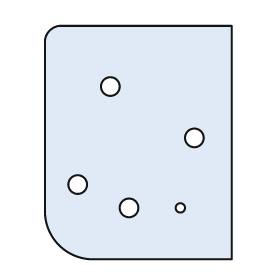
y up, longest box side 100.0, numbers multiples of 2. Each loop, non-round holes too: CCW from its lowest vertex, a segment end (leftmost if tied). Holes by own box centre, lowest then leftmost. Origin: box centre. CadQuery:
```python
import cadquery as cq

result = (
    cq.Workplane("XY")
    .moveTo(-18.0, -50.0)
    .lineTo(40.0, -50.0)
    .lineTo(40.0, 50.0)
    .lineTo(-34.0, 50.0)
    .threePointArc((-38.0, 48.0), (-40.0, 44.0))
    .lineTo(-40.0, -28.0)
    .threePointArc((-34.0, -44.0), (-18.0, -50.0))
    .close()
    .moveTo(-4.0, -28.0)
    .circle(4.0)
    .moveTo(18.0, -28.0)
    .circle(2.0)
    .moveTo(-26.0, -18.0)
    .circle(4.0)
    .moveTo(24.0, 2.0)
    .circle(4.0)
    .moveTo(-12.0, 24.0)
    .circle(4.0)
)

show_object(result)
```